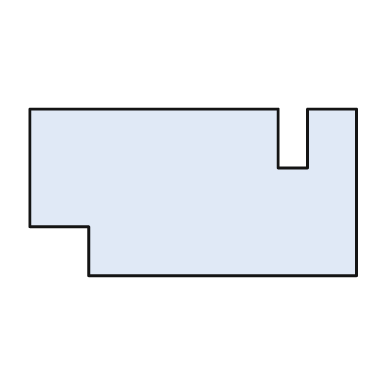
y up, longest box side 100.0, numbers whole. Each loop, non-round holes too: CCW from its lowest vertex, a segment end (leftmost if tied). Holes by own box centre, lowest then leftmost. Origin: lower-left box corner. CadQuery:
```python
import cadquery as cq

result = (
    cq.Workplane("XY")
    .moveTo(18.0, 0.0)
    .lineTo(100.0, 0.0)
    .lineTo(100.0, 51.0)
    .lineTo(85.0, 51.0)
    .lineTo(85.0, 33.0)
    .lineTo(76.0, 33.0)
    .lineTo(76.0, 51.0)
    .lineTo(0.0, 51.0)
    .lineTo(0.0, 15.0)
    .lineTo(18.0, 15.0)
    .close()
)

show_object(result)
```